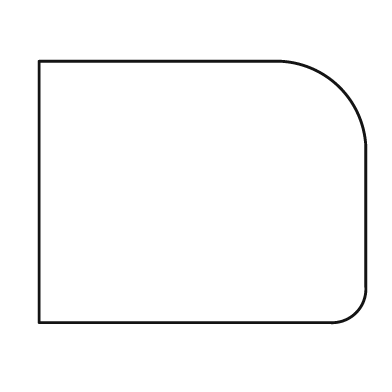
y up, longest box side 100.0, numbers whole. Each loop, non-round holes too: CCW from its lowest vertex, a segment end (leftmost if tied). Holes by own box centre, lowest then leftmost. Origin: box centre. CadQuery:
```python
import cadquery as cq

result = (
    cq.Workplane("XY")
    .moveTo(-50.0, -40.0)
    .lineTo(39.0, -40.0)
    .threePointArc((47.0, -37.0), (50.0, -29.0))
    .lineTo(50.0, 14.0)
    .threePointArc((42.0, 32.0), (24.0, 40.0))
    .lineTo(-50.0, 40.0)
    .close()
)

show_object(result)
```